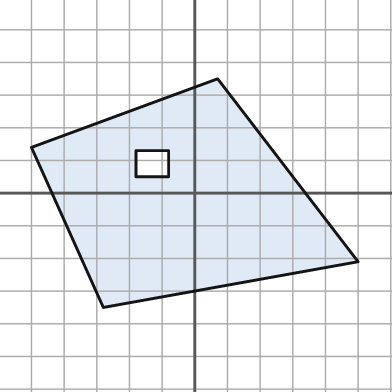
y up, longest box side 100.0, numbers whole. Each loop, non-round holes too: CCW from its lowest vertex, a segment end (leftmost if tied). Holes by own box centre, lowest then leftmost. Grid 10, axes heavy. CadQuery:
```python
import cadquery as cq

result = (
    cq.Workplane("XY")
    .moveTo(-28.0, -35.0)
    .lineTo(50.0, -21.0)
    .lineTo(7.0, 35.0)
    .lineTo(-50.0, 14.0)
    .close()
    .moveTo(-18.0, 5.0)
    .lineTo(-8.0, 5.0)
    .lineTo(-8.0, 13.0)
    .lineTo(-18.0, 13.0)
    .close()
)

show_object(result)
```